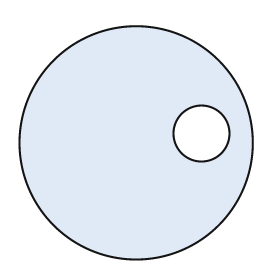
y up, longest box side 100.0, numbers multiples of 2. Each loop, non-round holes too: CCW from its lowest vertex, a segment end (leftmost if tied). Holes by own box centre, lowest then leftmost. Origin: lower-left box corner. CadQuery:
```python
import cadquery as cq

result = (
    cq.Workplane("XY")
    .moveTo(50.0, 50.0)
    .circle(50.0)
    .moveTo(78.0, 54.0)
    .circle(12.0)
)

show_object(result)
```